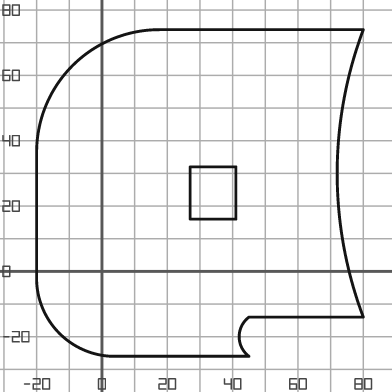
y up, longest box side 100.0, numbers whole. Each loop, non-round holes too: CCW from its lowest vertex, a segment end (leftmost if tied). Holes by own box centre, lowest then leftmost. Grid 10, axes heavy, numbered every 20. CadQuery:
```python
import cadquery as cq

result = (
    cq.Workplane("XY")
    .moveTo(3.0, -26.0)
    .lineTo(45.0, -26.0)
    .threePointArc((42.0, -20.0), (45.0, -14.0))
    .lineTo(80.0, -14.0)
    .threePointArc((72.0, 30.0), (80.0, 74.0))
    .lineTo(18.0, 74.0)
    .threePointArc((-9.0, 63.0), (-20.0, 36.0))
    .lineTo(-20.0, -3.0)
    .threePointArc((-13.0, -19.0), (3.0, -26.0))
    .close()
    .moveTo(27.0, 16.0)
    .lineTo(41.0, 16.0)
    .lineTo(41.0, 32.0)
    .lineTo(27.0, 32.0)
    .close()
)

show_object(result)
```